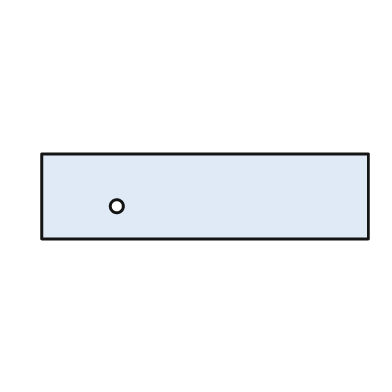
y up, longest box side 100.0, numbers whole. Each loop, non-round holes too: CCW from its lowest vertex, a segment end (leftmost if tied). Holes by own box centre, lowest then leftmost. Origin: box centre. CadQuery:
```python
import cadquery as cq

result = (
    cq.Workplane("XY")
    .moveTo(-50.0, -13.0)
    .lineTo(50.0, -13.0)
    .lineTo(50.0, 13.0)
    .lineTo(-50.0, 13.0)
    .close()
    .moveTo(-27.0, -3.0)
    .circle(2.0)
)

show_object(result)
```